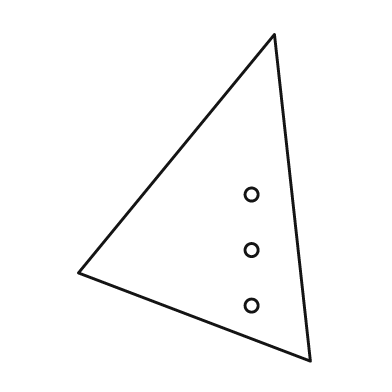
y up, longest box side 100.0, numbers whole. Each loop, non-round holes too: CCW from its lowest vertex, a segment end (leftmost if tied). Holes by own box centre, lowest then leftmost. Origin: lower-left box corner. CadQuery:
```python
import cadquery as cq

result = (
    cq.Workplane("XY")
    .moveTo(71.0, 0.0)
    .lineTo(60.0, 100.0)
    .lineTo(0.0, 27.0)
    .close()
    .moveTo(53.0, 17.0)
    .circle(2.0)
    .moveTo(53.0, 34.0)
    .circle(2.0)
    .moveTo(53.0, 51.0)
    .circle(2.0)
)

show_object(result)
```